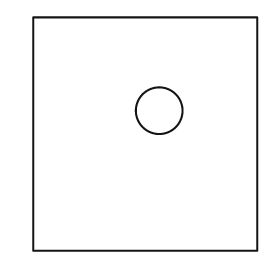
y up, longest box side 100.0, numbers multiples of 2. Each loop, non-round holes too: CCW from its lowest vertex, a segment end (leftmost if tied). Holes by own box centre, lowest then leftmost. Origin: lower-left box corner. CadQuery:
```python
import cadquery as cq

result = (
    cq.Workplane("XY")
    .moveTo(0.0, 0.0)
    .lineTo(96.0, 0.0)
    .lineTo(96.0, 100.0)
    .lineTo(0.0, 100.0)
    .close()
    .moveTo(54.0, 60.0)
    .circle(10.0)
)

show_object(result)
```